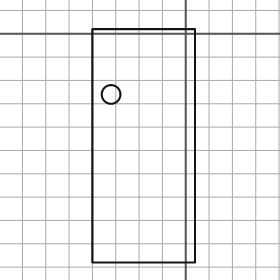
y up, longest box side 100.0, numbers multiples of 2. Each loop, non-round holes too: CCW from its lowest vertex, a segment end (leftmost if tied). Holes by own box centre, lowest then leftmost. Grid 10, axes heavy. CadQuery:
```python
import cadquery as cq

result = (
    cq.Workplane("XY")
    .moveTo(-40.0, -98.0)
    .lineTo(4.0, -98.0)
    .lineTo(4.0, 2.0)
    .lineTo(-40.0, 2.0)
    .close()
    .moveTo(-32.0, -26.0)
    .circle(4.0)
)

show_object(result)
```